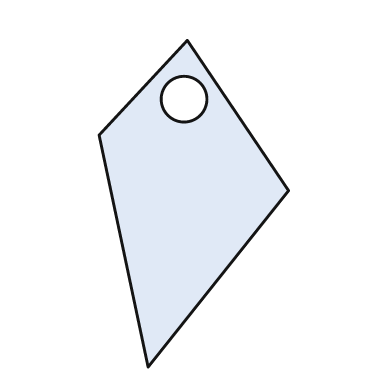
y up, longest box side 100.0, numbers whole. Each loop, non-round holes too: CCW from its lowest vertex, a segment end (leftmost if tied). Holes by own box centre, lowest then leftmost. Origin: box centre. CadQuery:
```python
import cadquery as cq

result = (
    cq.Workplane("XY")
    .moveTo(-14.0, -50.0)
    .lineTo(29.0, 4.0)
    .lineTo(-2.0, 50.0)
    .lineTo(-29.0, 21.0)
    .close()
    .moveTo(-3.0, 32.0)
    .circle(7.0)
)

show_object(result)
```